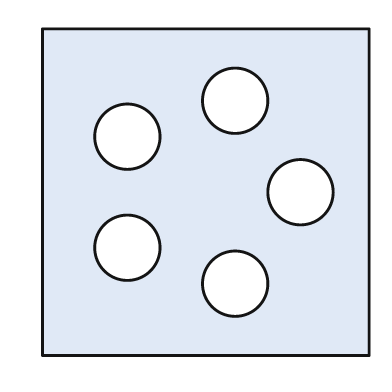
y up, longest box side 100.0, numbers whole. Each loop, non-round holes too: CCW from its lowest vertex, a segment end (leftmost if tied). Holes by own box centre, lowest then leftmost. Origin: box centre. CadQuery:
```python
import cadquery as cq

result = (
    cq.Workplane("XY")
    .moveTo(-50.0, -50.0)
    .lineTo(50.0, -50.0)
    .lineTo(50.0, 50.0)
    .lineTo(-50.0, 50.0)
    .close()
    .moveTo(9.0, -28.0)
    .circle(10.0)
    .moveTo(-24.0, -17.0)
    .circle(10.0)
    .moveTo(29.0, 0.0)
    .circle(10.0)
    .moveTo(-24.0, 17.0)
    .circle(10.0)
    .moveTo(9.0, 28.0)
    .circle(10.0)
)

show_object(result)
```